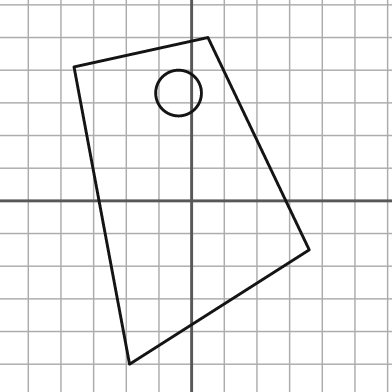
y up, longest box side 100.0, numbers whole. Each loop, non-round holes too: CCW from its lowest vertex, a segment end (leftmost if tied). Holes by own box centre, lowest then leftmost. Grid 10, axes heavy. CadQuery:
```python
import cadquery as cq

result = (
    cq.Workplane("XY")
    .moveTo(-19.0, -50.0)
    .lineTo(36.0, -15.0)
    .lineTo(5.0, 50.0)
    .lineTo(-36.0, 41.0)
    .close()
    .moveTo(-4.0, 33.0)
    .circle(7.0)
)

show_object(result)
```